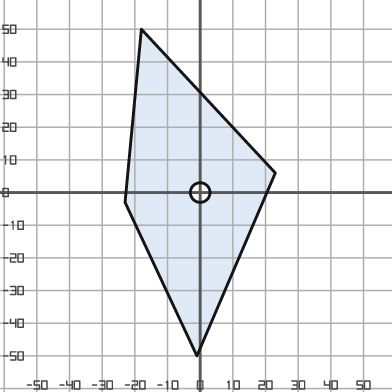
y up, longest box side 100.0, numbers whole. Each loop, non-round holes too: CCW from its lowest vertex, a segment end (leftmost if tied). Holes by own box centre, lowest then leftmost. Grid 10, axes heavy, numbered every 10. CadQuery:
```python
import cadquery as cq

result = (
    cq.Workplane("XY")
    .moveTo(-1.0, -50.0)
    .lineTo(23.0, 6.0)
    .lineTo(-18.0, 50.0)
    .lineTo(-23.0, -3.0)
    .close()
    .moveTo(0.0, 0.0)
    .circle(3.0)
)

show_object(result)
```